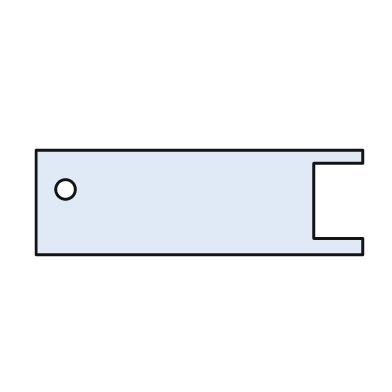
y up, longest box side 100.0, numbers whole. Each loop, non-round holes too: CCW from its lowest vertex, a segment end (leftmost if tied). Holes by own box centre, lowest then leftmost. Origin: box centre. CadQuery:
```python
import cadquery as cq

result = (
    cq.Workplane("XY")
    .moveTo(-50.0, -16.0)
    .lineTo(50.0, -16.0)
    .lineTo(50.0, -11.0)
    .lineTo(35.0, -11.0)
    .lineTo(35.0, 12.0)
    .lineTo(50.0, 12.0)
    .lineTo(50.0, 16.0)
    .lineTo(-50.0, 16.0)
    .close()
    .moveTo(-41.0, 4.0)
    .circle(3.0)
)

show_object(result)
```